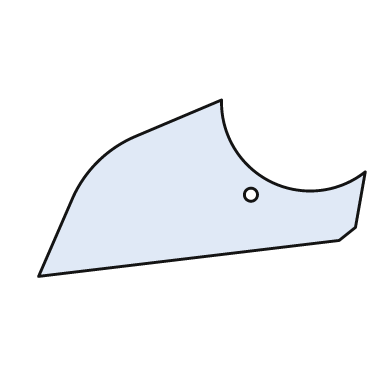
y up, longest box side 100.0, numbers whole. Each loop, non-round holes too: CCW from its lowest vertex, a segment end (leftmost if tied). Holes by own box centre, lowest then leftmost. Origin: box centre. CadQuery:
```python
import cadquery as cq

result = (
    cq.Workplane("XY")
    .moveTo(-50.0, -27.0)
    .lineTo(42.0, -16.0)
    .lineTo(47.0, -12.0)
    .lineTo(50.0, 5.0)
    .threePointArc((21.0, 2.0), (6.0, 27.0))
    .lineTo(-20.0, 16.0)
    .threePointArc((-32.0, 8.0), (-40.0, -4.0))
    .close()
    .moveTo(15.0, -2.0)
    .circle(2.0)
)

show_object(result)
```